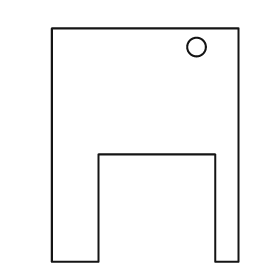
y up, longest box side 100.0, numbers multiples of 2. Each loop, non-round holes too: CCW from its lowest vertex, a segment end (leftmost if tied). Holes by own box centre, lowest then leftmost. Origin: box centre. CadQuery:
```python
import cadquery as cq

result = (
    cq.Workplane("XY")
    .moveTo(-40.0, -50.0)
    .lineTo(-20.0, -50.0)
    .lineTo(-20.0, -4.0)
    .lineTo(30.0, -4.0)
    .lineTo(30.0, -50.0)
    .lineTo(40.0, -50.0)
    .lineTo(40.0, 50.0)
    .lineTo(-40.0, 50.0)
    .close()
    .moveTo(22.0, 42.0)
    .circle(4.0)
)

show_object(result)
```